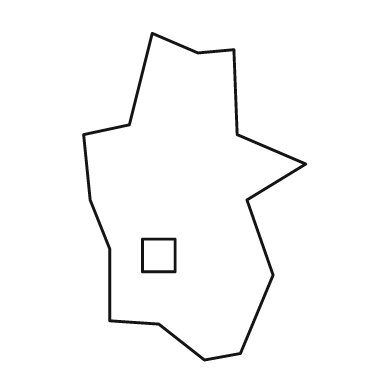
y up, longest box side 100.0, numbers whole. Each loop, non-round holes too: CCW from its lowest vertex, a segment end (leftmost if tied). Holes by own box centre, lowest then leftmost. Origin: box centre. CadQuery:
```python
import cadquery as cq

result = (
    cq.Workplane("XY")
    .moveTo(3.0, -50.0)
    .lineTo(14.0, -48.0)
    .lineTo(24.0, -24.0)
    .lineTo(16.0, -1.0)
    .lineTo(34.0, 10.0)
    .lineTo(13.0, 19.0)
    .lineTo(12.0, 45.0)
    .lineTo(1.0, 44.0)
    .lineTo(-13.0, 50.0)
    .lineTo(-20.0, 22.0)
    .lineTo(-34.0, 19.0)
    .lineTo(-32.0, -1.0)
    .lineTo(-26.0, -16.0)
    .lineTo(-26.0, -38.0)
    .lineTo(-11.0, -39.0)
    .close()
    .moveTo(-16.0, -23.0)
    .lineTo(-6.0, -23.0)
    .lineTo(-6.0, -13.0)
    .lineTo(-16.0, -13.0)
    .close()
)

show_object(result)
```